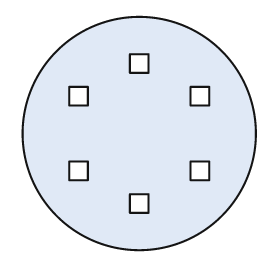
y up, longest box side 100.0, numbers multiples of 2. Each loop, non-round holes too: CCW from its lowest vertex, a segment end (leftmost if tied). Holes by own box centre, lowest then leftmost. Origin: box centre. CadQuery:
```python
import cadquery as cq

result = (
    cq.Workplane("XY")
    .moveTo(0.0, 0.0)
    .circle(50.0)
    .moveTo(-4.0, -34.0)
    .lineTo(4.0, -34.0)
    .lineTo(4.0, -26.0)
    .lineTo(-4.0, -26.0)
    .close()
    .moveTo(-30.0, -20.0)
    .lineTo(-22.0, -20.0)
    .lineTo(-22.0, -12.0)
    .lineTo(-30.0, -12.0)
    .close()
    .moveTo(22.0, -20.0)
    .lineTo(30.0, -20.0)
    .lineTo(30.0, -12.0)
    .lineTo(22.0, -12.0)
    .close()
    .moveTo(-30.0, 12.0)
    .lineTo(-22.0, 12.0)
    .lineTo(-22.0, 20.0)
    .lineTo(-30.0, 20.0)
    .close()
    .moveTo(22.0, 12.0)
    .lineTo(30.0, 12.0)
    .lineTo(30.0, 20.0)
    .lineTo(22.0, 20.0)
    .close()
    .moveTo(-4.0, 26.0)
    .lineTo(4.0, 26.0)
    .lineTo(4.0, 34.0)
    .lineTo(-4.0, 34.0)
    .close()
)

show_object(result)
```